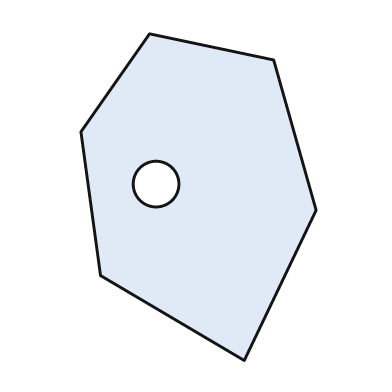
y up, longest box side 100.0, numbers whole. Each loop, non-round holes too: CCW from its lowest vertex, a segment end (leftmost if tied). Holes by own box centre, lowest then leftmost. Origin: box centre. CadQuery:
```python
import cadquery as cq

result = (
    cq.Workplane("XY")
    .moveTo(14.0, -50.0)
    .lineTo(36.0, -4.0)
    .lineTo(23.0, 42.0)
    .lineTo(-15.0, 50.0)
    .lineTo(-36.0, 20.0)
    .lineTo(-30.0, -24.0)
    .close()
    .moveTo(-13.0, 4.0)
    .circle(7.0)
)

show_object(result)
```